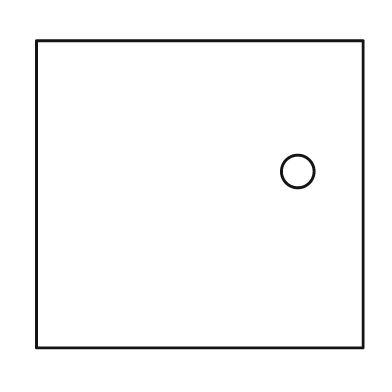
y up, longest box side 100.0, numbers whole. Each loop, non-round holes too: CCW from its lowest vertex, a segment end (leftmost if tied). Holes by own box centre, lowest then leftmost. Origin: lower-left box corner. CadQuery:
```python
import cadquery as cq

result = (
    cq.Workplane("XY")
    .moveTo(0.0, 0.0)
    .lineTo(100.0, 0.0)
    .lineTo(100.0, 94.0)
    .lineTo(0.0, 94.0)
    .close()
    .moveTo(80.0, 54.0)
    .circle(5.0)
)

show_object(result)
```